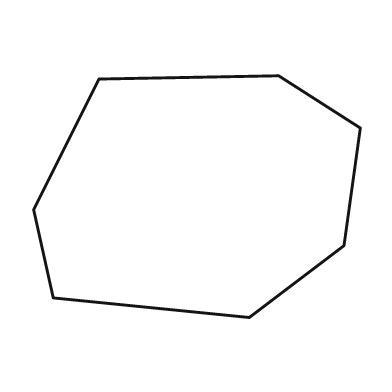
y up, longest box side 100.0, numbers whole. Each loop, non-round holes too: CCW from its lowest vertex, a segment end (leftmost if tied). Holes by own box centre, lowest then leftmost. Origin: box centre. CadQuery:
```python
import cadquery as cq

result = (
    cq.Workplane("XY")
    .moveTo(16.0, -37.0)
    .lineTo(45.0, -15.0)
    .lineTo(50.0, 21.0)
    .lineTo(25.0, 37.0)
    .lineTo(-30.0, 36.0)
    .lineTo(-50.0, -4.0)
    .lineTo(-44.0, -31.0)
    .close()
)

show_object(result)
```